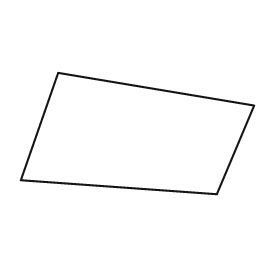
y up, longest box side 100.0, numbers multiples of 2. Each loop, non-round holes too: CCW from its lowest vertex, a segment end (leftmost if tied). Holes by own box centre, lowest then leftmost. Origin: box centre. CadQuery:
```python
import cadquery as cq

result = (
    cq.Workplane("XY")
    .moveTo(34.0, -26.0)
    .lineTo(50.0, 12.0)
    .lineTo(-34.0, 26.0)
    .lineTo(-50.0, -20.0)
    .close()
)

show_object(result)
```